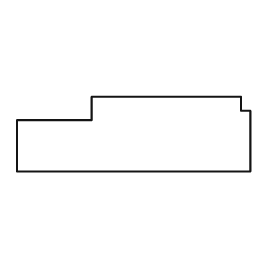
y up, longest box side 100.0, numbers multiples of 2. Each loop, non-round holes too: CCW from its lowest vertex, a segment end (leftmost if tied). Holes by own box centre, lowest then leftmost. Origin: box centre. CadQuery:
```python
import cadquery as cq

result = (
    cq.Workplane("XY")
    .moveTo(-50.0, -16.0)
    .lineTo(50.0, -16.0)
    .lineTo(50.0, 10.0)
    .lineTo(46.0, 10.0)
    .lineTo(46.0, 16.0)
    .lineTo(-18.0, 16.0)
    .lineTo(-18.0, 6.0)
    .lineTo(-50.0, 6.0)
    .close()
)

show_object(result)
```